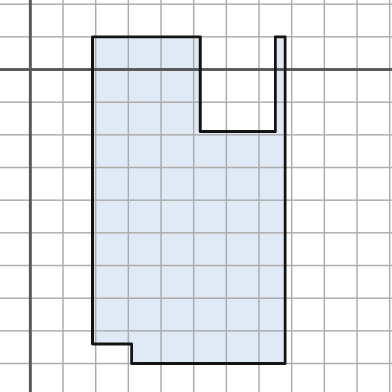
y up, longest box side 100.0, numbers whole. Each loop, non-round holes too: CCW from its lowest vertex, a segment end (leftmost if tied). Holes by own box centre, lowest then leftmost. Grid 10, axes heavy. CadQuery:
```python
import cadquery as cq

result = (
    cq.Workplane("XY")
    .moveTo(31.0, -90.0)
    .lineTo(78.0, -90.0)
    .lineTo(78.0, 10.0)
    .lineTo(75.0, 10.0)
    .lineTo(75.0, -19.0)
    .lineTo(52.0, -19.0)
    .lineTo(52.0, 10.0)
    .lineTo(19.0, 10.0)
    .lineTo(19.0, -84.0)
    .lineTo(31.0, -84.0)
    .close()
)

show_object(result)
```